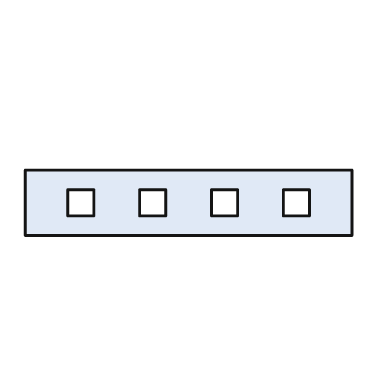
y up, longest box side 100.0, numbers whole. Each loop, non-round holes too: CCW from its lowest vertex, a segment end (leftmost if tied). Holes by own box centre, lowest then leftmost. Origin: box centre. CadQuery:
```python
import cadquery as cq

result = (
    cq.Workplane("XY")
    .moveTo(-50.0, -10.0)
    .lineTo(50.0, -10.0)
    .lineTo(50.0, 10.0)
    .lineTo(-50.0, 10.0)
    .close()
    .moveTo(-37.0, -4.0)
    .lineTo(-29.0, -4.0)
    .lineTo(-29.0, 4.0)
    .lineTo(-37.0, 4.0)
    .close()
    .moveTo(-15.0, -4.0)
    .lineTo(-7.0, -4.0)
    .lineTo(-7.0, 4.0)
    .lineTo(-15.0, 4.0)
    .close()
    .moveTo(7.0, -4.0)
    .lineTo(15.0, -4.0)
    .lineTo(15.0, 4.0)
    .lineTo(7.0, 4.0)
    .close()
    .moveTo(29.0, -4.0)
    .lineTo(37.0, -4.0)
    .lineTo(37.0, 4.0)
    .lineTo(29.0, 4.0)
    .close()
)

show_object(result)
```